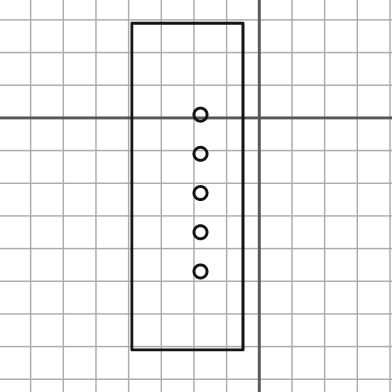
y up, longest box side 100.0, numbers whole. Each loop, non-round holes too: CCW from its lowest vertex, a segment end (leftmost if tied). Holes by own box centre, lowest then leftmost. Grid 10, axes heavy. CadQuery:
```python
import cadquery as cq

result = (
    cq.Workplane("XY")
    .moveTo(-39.0, -71.0)
    .lineTo(-5.0, -71.0)
    .lineTo(-5.0, 29.0)
    .lineTo(-39.0, 29.0)
    .close()
    .moveTo(-18.0, -47.0)
    .circle(2.0)
    .moveTo(-18.0, -35.0)
    .circle(2.0)
    .moveTo(-18.0, -23.0)
    .circle(2.0)
    .moveTo(-18.0, -11.0)
    .circle(2.0)
    .moveTo(-18.0, 1.0)
    .circle(2.0)
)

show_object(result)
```